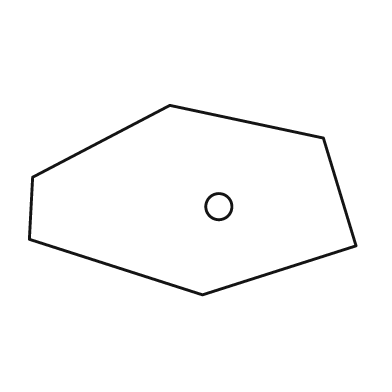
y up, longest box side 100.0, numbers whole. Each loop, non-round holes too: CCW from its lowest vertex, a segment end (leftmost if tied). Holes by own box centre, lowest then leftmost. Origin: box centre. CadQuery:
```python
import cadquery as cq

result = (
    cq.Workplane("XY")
    .moveTo(3.0, -29.0)
    .lineTo(50.0, -14.0)
    .lineTo(40.0, 19.0)
    .lineTo(-7.0, 29.0)
    .lineTo(-49.0, 7.0)
    .lineTo(-50.0, -12.0)
    .close()
    .moveTo(8.0, -2.0)
    .circle(4.0)
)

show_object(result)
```